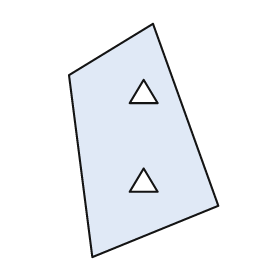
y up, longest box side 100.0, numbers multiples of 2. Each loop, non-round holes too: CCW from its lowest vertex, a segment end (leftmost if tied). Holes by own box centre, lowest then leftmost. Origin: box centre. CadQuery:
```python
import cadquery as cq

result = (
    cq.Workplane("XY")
    .moveTo(-22.0, -50.0)
    .lineTo(32.0, -28.0)
    .lineTo(4.0, 50.0)
    .lineTo(-32.0, 28.0)
    .close()
    .moveTo(-6.0, -22.0)
    .lineTo(6.0, -22.0)
    .lineTo(0.0, -12.0)
    .close()
    .moveTo(-6.0, 16.0)
    .lineTo(6.0, 16.0)
    .lineTo(0.0, 26.0)
    .close()
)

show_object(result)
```